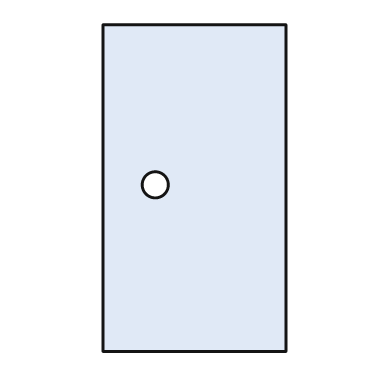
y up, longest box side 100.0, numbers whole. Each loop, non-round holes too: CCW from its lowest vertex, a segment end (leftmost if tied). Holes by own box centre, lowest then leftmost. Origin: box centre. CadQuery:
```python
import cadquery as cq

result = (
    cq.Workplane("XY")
    .moveTo(-28.0, -50.0)
    .lineTo(28.0, -50.0)
    .lineTo(28.0, 50.0)
    .lineTo(-28.0, 50.0)
    .close()
    .moveTo(-12.0, 1.0)
    .circle(4.0)
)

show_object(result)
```